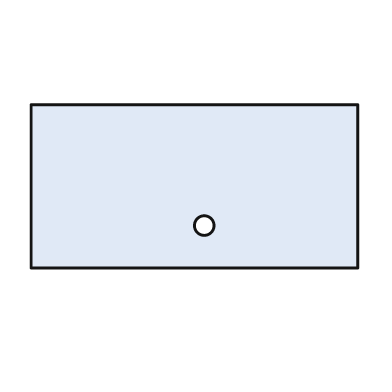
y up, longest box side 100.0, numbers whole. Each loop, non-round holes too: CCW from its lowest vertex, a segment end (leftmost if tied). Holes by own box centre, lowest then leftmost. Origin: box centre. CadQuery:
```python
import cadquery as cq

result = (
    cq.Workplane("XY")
    .moveTo(-50.0, -25.0)
    .lineTo(50.0, -25.0)
    .lineTo(50.0, 25.0)
    .lineTo(-50.0, 25.0)
    .close()
    .moveTo(3.0, -12.0)
    .circle(3.0)
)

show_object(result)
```